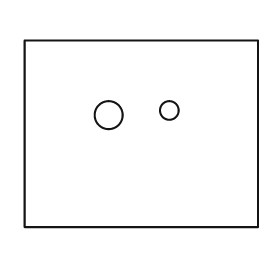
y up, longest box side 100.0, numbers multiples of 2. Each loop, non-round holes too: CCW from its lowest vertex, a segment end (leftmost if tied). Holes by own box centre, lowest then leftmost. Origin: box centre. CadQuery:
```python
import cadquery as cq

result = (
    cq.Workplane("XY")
    .moveTo(-50.0, -40.0)
    .lineTo(50.0, -40.0)
    .lineTo(50.0, 40.0)
    .lineTo(-50.0, 40.0)
    .close()
    .moveTo(-14.0, 8.0)
    .circle(6.0)
    .moveTo(12.0, 10.0)
    .circle(4.0)
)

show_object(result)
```